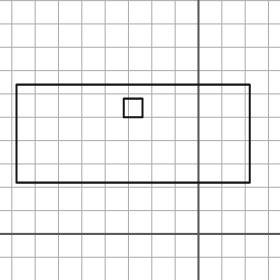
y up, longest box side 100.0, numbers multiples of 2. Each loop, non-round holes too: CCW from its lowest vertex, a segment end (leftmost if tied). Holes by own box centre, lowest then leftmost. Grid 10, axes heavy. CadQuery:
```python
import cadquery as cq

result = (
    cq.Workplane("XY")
    .moveTo(-78.0, 22.0)
    .lineTo(22.0, 22.0)
    .lineTo(22.0, 64.0)
    .lineTo(-78.0, 64.0)
    .close()
    .moveTo(-32.0, 50.0)
    .lineTo(-24.0, 50.0)
    .lineTo(-24.0, 58.0)
    .lineTo(-32.0, 58.0)
    .close()
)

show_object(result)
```